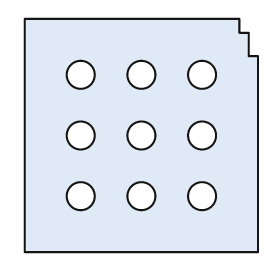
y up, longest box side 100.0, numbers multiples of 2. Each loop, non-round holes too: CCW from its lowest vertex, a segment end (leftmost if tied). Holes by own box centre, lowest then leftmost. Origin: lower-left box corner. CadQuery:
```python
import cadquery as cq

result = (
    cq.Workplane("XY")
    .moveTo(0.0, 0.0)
    .lineTo(100.0, 0.0)
    .lineTo(100.0, 84.0)
    .lineTo(96.0, 84.0)
    .lineTo(96.0, 94.0)
    .lineTo(92.0, 94.0)
    .lineTo(92.0, 100.0)
    .lineTo(0.0, 100.0)
    .close()
    .moveTo(24.0, 24.0)
    .circle(6.0)
    .moveTo(50.0, 24.0)
    .circle(6.0)
    .moveTo(76.0, 24.0)
    .circle(6.0)
    .moveTo(24.0, 50.0)
    .circle(6.0)
    .moveTo(50.0, 50.0)
    .circle(6.0)
    .moveTo(76.0, 50.0)
    .circle(6.0)
    .moveTo(24.0, 76.0)
    .circle(6.0)
    .moveTo(50.0, 76.0)
    .circle(6.0)
    .moveTo(76.0, 76.0)
    .circle(6.0)
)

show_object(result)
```